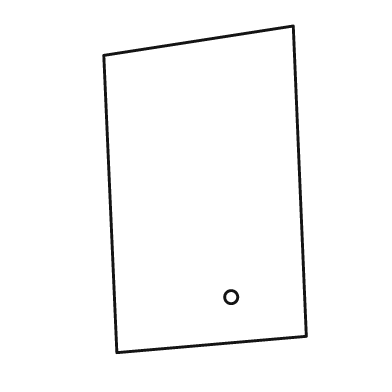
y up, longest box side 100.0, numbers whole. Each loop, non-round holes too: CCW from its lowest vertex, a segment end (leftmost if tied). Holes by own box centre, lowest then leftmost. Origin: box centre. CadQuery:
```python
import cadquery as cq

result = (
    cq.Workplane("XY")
    .moveTo(-27.0, -50.0)
    .lineTo(31.0, -45.0)
    .lineTo(27.0, 50.0)
    .lineTo(-31.0, 41.0)
    .close()
    .moveTo(8.0, -33.0)
    .circle(2.0)
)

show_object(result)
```